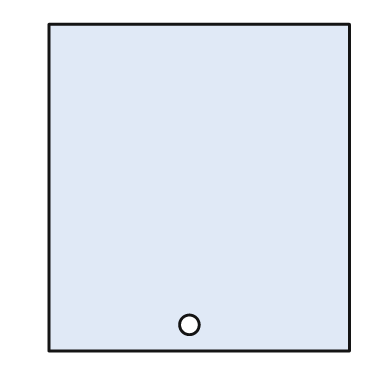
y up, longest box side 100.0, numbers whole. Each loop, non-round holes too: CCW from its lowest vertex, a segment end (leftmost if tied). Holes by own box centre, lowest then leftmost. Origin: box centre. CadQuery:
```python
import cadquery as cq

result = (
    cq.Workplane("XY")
    .moveTo(-46.0, -50.0)
    .lineTo(46.0, -50.0)
    .lineTo(46.0, 50.0)
    .lineTo(-46.0, 50.0)
    .close()
    .moveTo(-3.0, -42.0)
    .circle(3.0)
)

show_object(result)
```